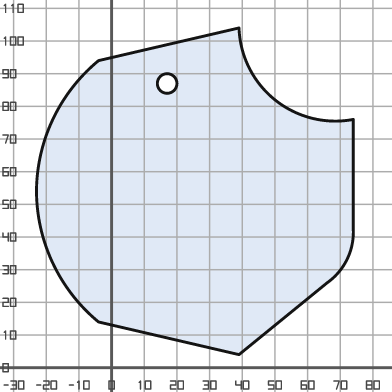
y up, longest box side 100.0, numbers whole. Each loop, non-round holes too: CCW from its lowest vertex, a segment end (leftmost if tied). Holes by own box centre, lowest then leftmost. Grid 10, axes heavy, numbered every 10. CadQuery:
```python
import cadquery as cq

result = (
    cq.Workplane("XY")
    .moveTo(39.0, 4.0)
    .lineTo(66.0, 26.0)
    .threePointArc((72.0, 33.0), (74.0, 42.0))
    .lineTo(74.0, 76.0)
    .threePointArc((50.0, 82.0), (39.0, 104.0))
    .lineTo(-4.0, 94.0)
    .threePointArc((-18.0, 76.0), (-23.0, 54.0))
    .threePointArc((-18.0, 32.0), (-4.0, 14.0))
    .close()
    .moveTo(17.0, 87.0)
    .circle(3.0)
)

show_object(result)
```